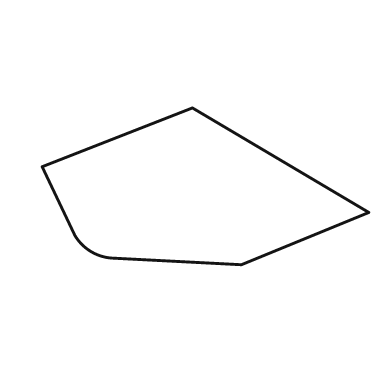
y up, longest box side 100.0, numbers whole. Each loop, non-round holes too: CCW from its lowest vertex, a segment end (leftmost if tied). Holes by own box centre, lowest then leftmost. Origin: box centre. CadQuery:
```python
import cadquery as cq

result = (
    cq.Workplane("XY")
    .moveTo(11.0, -24.0)
    .lineTo(50.0, -8.0)
    .lineTo(-4.0, 24.0)
    .lineTo(-50.0, 6.0)
    .lineTo(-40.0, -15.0)
    .threePointArc((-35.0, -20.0), (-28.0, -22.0))
    .close()
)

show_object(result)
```